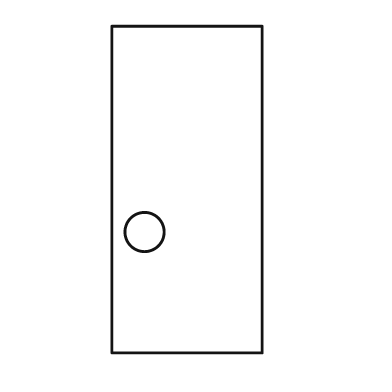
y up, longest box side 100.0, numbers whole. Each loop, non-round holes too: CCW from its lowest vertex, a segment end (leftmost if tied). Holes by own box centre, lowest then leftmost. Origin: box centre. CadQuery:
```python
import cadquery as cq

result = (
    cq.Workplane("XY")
    .moveTo(-23.0, -50.0)
    .lineTo(23.0, -50.0)
    .lineTo(23.0, 50.0)
    .lineTo(-23.0, 50.0)
    .close()
    .moveTo(-13.0, -13.0)
    .circle(6.0)
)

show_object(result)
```